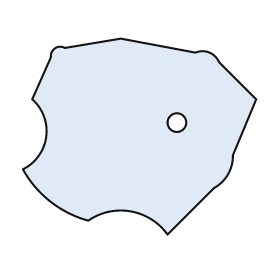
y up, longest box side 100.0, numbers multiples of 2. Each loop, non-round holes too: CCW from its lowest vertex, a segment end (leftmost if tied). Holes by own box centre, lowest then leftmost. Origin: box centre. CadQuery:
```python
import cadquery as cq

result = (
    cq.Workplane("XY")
    .moveTo(12.0, -42.0)
    .lineTo(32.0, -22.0)
    .threePointArc((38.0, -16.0), (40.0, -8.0))
    .lineTo(50.0, 16.0)
    .lineTo(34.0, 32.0)
    .threePointArc((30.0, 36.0), (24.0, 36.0))
    .lineTo(-8.0, 42.0)
    .lineTo(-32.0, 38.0)
    .threePointArc((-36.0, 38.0), (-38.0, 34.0))
    .lineTo(-46.0, 16.0)
    .threePointArc((-40.0, 0.0), (-50.0, -14.0))
    .threePointArc((-38.0, -28.0), (-22.0, -36.0))
    .threePointArc((-4.0, -32.0), (12.0, -42.0))
    .close()
    .moveTo(16.0, 6.0)
    .circle(4.0)
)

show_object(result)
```